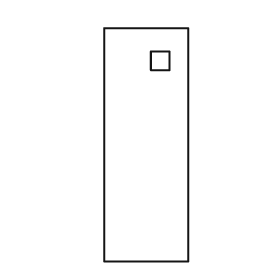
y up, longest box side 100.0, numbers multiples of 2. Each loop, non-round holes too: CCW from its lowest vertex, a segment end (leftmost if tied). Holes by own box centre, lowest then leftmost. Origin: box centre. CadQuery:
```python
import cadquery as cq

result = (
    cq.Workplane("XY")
    .moveTo(-18.0, -50.0)
    .lineTo(18.0, -50.0)
    .lineTo(18.0, 50.0)
    .lineTo(-18.0, 50.0)
    .close()
    .moveTo(2.0, 32.0)
    .lineTo(10.0, 32.0)
    .lineTo(10.0, 40.0)
    .lineTo(2.0, 40.0)
    .close()
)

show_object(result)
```